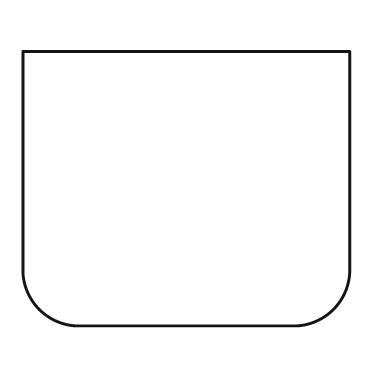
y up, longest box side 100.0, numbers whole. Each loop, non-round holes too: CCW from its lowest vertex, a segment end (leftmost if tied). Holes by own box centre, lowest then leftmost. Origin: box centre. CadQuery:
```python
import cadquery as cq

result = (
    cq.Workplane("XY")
    .moveTo(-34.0, -42.0)
    .lineTo(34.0, -42.0)
    .threePointArc((45.0, -37.0), (50.0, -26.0))
    .lineTo(50.0, 42.0)
    .lineTo(-50.0, 42.0)
    .lineTo(-50.0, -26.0)
    .threePointArc((-45.0, -37.0), (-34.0, -42.0))
    .close()
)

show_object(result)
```